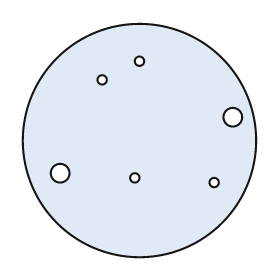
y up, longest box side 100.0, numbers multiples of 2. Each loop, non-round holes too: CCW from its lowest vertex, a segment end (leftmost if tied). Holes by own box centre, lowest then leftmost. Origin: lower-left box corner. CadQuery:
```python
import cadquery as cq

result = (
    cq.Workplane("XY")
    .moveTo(50.0, 50.0)
    .circle(50.0)
    .moveTo(82.0, 32.0)
    .circle(2.0)
    .moveTo(48.0, 34.0)
    .circle(2.0)
    .moveTo(16.0, 36.0)
    .circle(4.0)
    .moveTo(90.0, 60.0)
    .circle(4.0)
    .moveTo(34.0, 76.0)
    .circle(2.0)
    .moveTo(50.0, 84.0)
    .circle(2.0)
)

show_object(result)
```